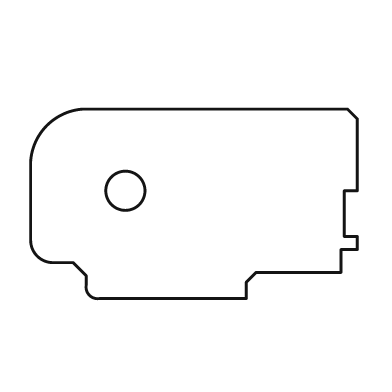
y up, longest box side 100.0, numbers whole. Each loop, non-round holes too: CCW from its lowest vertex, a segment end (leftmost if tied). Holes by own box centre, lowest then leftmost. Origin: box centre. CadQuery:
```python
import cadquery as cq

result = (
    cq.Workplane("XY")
    .moveTo(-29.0, -29.0)
    .lineTo(16.0, -29.0)
    .lineTo(16.0, -24.0)
    .lineTo(19.0, -21.0)
    .lineTo(45.0, -21.0)
    .lineTo(45.0, -14.0)
    .lineTo(50.0, -14.0)
    .lineTo(50.0, -10.0)
    .lineTo(46.0, -10.0)
    .lineTo(46.0, 4.0)
    .lineTo(50.0, 4.0)
    .lineTo(50.0, 26.0)
    .lineTo(47.0, 29.0)
    .lineTo(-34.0, 29.0)
    .threePointArc((-45.0, 24.0), (-50.0, 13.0))
    .lineTo(-50.0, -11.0)
    .threePointArc((-48.0, -16.0), (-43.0, -18.0))
    .lineTo(-37.0, -18.0)
    .lineTo(-33.0, -22.0)
    .lineTo(-33.0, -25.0)
    .threePointArc((-32.0, -28.0), (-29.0, -29.0))
    .close()
    .moveTo(-21.0, 4.0)
    .circle(6.0)
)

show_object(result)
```